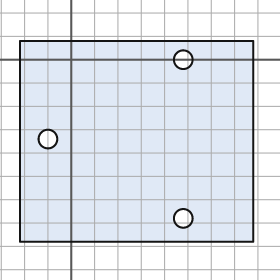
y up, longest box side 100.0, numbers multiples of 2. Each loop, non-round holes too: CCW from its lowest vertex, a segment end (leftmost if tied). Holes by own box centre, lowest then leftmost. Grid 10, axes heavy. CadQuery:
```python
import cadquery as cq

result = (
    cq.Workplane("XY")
    .moveTo(-22.0, -78.0)
    .lineTo(78.0, -78.0)
    .lineTo(78.0, 8.0)
    .lineTo(-22.0, 8.0)
    .close()
    .moveTo(48.0, -68.0)
    .circle(4.0)
    .moveTo(-10.0, -34.0)
    .circle(4.0)
    .moveTo(48.0, 0.0)
    .circle(4.0)
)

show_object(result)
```